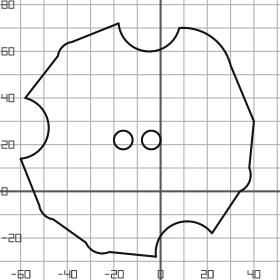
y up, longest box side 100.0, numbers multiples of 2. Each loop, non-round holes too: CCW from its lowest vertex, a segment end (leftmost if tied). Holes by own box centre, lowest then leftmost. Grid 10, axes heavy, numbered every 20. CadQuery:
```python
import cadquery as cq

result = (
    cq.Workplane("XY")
    .moveTo(-2.0, -28.0)
    .threePointArc((6.0, -14.0), (22.0, -18.0))
    .lineTo(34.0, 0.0)
    .threePointArc((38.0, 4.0), (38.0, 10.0))
    .lineTo(40.0, 30.0)
    .lineTo(30.0, 54.0)
    .threePointArc((22.0, 66.0), (8.0, 70.0))
    .threePointArc((-6.0, 60.0), (-18.0, 72.0))
    .lineTo(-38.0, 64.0)
    .threePointArc((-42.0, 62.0), (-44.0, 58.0))
    .lineTo(-58.0, 40.0)
    .threePointArc((-48.0, 26.0), (-60.0, 14.0))
    .lineTo(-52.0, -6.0)
    .threePointArc((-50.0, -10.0), (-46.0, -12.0))
    .lineTo(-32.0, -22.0)
    .threePointArc((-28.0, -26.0), (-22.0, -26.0))
    .close()
    .moveTo(-16.0, 22.0)
    .circle(4.0)
    .moveTo(-4.0, 22.0)
    .circle(4.0)
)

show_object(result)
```